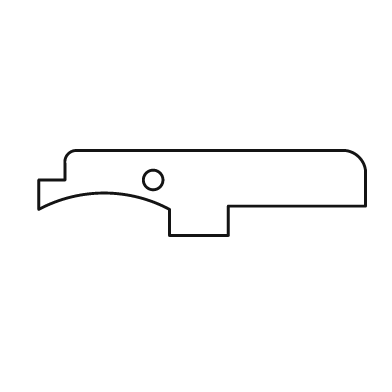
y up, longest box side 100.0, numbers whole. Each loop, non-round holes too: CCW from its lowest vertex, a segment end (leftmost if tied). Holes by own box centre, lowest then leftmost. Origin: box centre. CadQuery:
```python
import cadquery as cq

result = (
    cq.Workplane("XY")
    .moveTo(-10.0, -13.0)
    .lineTo(8.0, -13.0)
    .lineTo(8.0, -4.0)
    .lineTo(50.0, -4.0)
    .lineTo(50.0, 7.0)
    .threePointArc((48.0, 11.0), (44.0, 13.0))
    .lineTo(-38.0, 13.0)
    .threePointArc((-41.0, 12.0), (-42.0, 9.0))
    .lineTo(-42.0, 4.0)
    .lineTo(-50.0, 4.0)
    .lineTo(-50.0, -5.0)
    .threePointArc((-30.0, 0.0), (-10.0, -5.0))
    .close()
    .moveTo(-15.0, 4.0)
    .circle(3.0)
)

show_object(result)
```